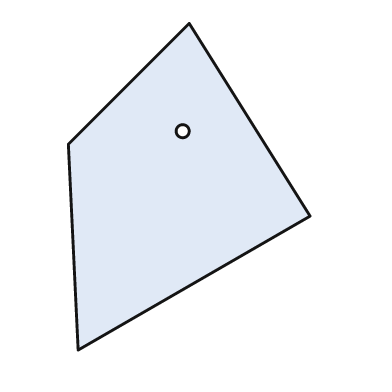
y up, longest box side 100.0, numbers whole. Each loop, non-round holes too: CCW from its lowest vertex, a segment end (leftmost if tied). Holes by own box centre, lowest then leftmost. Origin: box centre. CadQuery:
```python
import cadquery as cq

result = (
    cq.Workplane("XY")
    .moveTo(-34.0, -50.0)
    .lineTo(37.0, -9.0)
    .lineTo(0.0, 50.0)
    .lineTo(-37.0, 13.0)
    .close()
    .moveTo(-2.0, 17.0)
    .circle(2.0)
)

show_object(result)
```